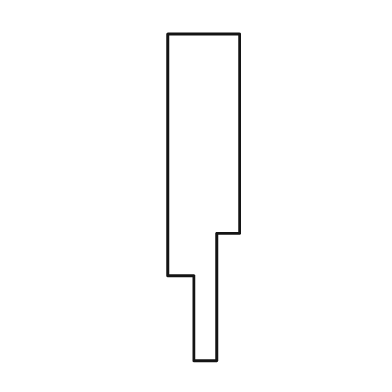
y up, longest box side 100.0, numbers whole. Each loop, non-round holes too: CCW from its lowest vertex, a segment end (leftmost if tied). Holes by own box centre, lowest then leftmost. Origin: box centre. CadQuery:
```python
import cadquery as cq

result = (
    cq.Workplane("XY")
    .moveTo(-3.0, -50.0)
    .lineTo(4.0, -50.0)
    .lineTo(4.0, -11.0)
    .lineTo(11.0, -11.0)
    .lineTo(11.0, 50.0)
    .lineTo(-11.0, 50.0)
    .lineTo(-11.0, -24.0)
    .lineTo(-3.0, -24.0)
    .close()
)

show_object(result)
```